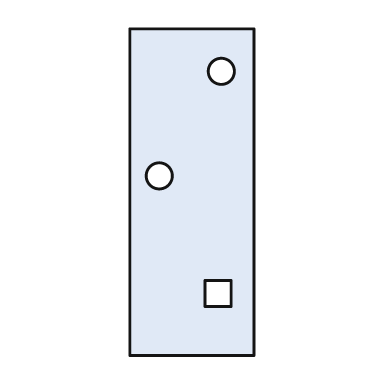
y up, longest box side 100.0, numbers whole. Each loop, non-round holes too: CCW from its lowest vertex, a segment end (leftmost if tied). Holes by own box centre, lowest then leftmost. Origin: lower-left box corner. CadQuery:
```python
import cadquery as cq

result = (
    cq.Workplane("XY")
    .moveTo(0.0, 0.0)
    .lineTo(38.0, 0.0)
    .lineTo(38.0, 100.0)
    .lineTo(0.0, 100.0)
    .close()
    .moveTo(23.0, 15.0)
    .lineTo(31.0, 15.0)
    .lineTo(31.0, 23.0)
    .lineTo(23.0, 23.0)
    .close()
    .moveTo(9.0, 55.0)
    .circle(4.0)
    .moveTo(28.0, 87.0)
    .circle(4.0)
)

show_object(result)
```